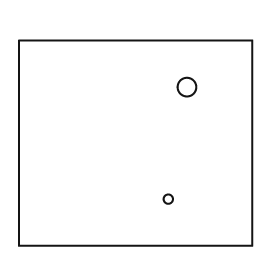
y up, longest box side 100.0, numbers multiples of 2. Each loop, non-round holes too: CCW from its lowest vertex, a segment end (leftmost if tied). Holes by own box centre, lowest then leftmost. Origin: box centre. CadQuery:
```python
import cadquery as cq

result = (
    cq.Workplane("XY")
    .moveTo(-50.0, -44.0)
    .lineTo(50.0, -44.0)
    .lineTo(50.0, 44.0)
    .lineTo(-50.0, 44.0)
    .close()
    .moveTo(14.0, -24.0)
    .circle(2.0)
    .moveTo(22.0, 24.0)
    .circle(4.0)
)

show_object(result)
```